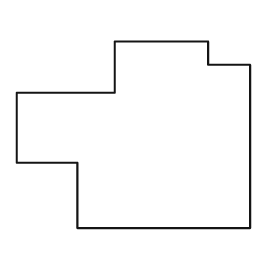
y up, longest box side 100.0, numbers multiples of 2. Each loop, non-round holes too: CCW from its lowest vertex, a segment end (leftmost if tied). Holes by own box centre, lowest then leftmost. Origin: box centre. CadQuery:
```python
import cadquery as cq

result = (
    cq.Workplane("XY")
    .moveTo(-24.0, -40.0)
    .lineTo(50.0, -40.0)
    .lineTo(50.0, 30.0)
    .lineTo(32.0, 30.0)
    .lineTo(32.0, 40.0)
    .lineTo(-8.0, 40.0)
    .lineTo(-8.0, 18.0)
    .lineTo(-50.0, 18.0)
    .lineTo(-50.0, -12.0)
    .lineTo(-24.0, -12.0)
    .close()
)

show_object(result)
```